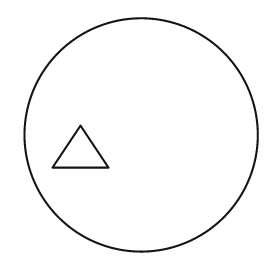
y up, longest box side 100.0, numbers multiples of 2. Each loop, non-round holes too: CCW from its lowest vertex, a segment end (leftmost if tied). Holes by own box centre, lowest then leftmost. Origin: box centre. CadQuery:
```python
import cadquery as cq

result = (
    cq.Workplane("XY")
    .moveTo(0.0, 0.0)
    .circle(50.0)
    .moveTo(-38.0, -14.0)
    .lineTo(-14.0, -14.0)
    .lineTo(-26.0, 4.0)
    .close()
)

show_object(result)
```